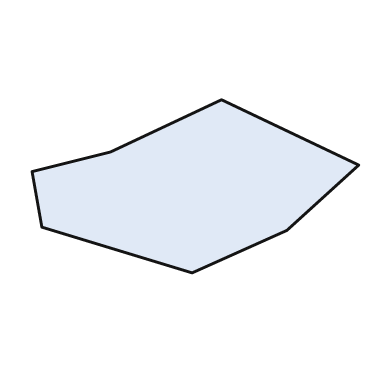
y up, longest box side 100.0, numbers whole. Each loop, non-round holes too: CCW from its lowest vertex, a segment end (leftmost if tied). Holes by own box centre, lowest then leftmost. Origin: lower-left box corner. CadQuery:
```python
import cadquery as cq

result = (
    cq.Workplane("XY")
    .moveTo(49.0, 0.0)
    .lineTo(78.0, 13.0)
    .lineTo(100.0, 33.0)
    .lineTo(58.0, 53.0)
    .lineTo(24.0, 37.0)
    .lineTo(0.0, 31.0)
    .lineTo(3.0, 14.0)
    .close()
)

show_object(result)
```